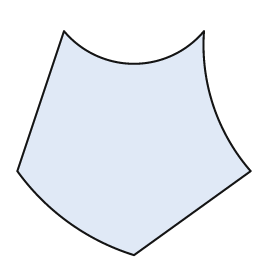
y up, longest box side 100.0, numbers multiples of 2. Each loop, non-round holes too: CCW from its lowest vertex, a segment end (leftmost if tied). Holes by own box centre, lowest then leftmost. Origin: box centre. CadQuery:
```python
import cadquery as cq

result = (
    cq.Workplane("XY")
    .moveTo(0.0, -48.0)
    .lineTo(50.0, -12.0)
    .threePointArc((34.0, 16.0), (30.0, 48.0))
    .threePointArc((0.0, 34.0), (-30.0, 48.0))
    .lineTo(-50.0, -12.0)
    .threePointArc((-28.0, -34.0), (0.0, -48.0))
    .close()
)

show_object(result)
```